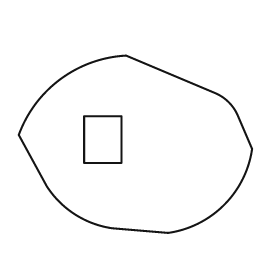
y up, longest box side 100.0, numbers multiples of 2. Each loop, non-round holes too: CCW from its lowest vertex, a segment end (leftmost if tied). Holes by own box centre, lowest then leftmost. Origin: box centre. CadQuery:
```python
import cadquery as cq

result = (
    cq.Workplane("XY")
    .moveTo(14.0, -38.0)
    .threePointArc((38.0, -26.0), (50.0, -2.0))
    .lineTo(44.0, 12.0)
    .threePointArc((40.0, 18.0), (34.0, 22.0))
    .lineTo(-4.0, 38.0)
    .threePointArc((-32.0, 28.0), (-50.0, 4.0))
    .lineTo(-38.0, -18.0)
    .threePointArc((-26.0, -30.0), (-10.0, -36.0))
    .close()
    .moveTo(-22.0, -8.0)
    .lineTo(-6.0, -8.0)
    .lineTo(-6.0, 12.0)
    .lineTo(-22.0, 12.0)
    .close()
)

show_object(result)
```